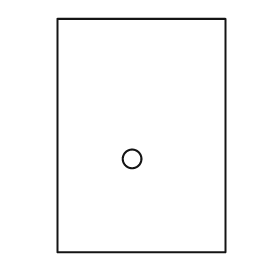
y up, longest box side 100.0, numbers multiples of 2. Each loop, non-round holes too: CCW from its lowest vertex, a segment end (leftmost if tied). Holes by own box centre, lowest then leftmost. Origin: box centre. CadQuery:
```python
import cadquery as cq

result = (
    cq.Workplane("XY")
    .moveTo(-36.0, -50.0)
    .lineTo(36.0, -50.0)
    .lineTo(36.0, 50.0)
    .lineTo(-36.0, 50.0)
    .close()
    .moveTo(-4.0, -10.0)
    .circle(4.0)
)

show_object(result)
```